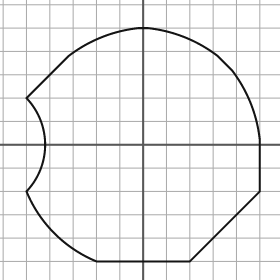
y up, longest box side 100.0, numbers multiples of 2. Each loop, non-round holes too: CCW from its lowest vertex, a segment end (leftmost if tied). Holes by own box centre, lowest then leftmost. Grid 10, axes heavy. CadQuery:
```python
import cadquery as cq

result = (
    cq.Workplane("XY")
    .moveTo(-20.0, -50.0)
    .lineTo(20.0, -50.0)
    .lineTo(50.0, -20.0)
    .lineTo(50.0, 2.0)
    .threePointArc((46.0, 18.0), (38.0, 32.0))
    .lineTo(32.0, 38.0)
    .threePointArc((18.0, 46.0), (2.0, 50.0))
    .lineTo(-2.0, 50.0)
    .threePointArc((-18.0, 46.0), (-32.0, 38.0))
    .lineTo(-50.0, 20.0)
    .threePointArc((-42.0, 0.0), (-50.0, -20.0))
    .threePointArc((-38.0, -38.0), (-20.0, -50.0))
    .close()
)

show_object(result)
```